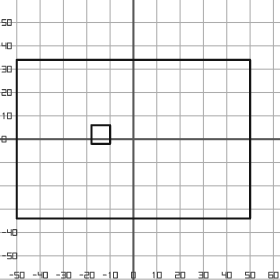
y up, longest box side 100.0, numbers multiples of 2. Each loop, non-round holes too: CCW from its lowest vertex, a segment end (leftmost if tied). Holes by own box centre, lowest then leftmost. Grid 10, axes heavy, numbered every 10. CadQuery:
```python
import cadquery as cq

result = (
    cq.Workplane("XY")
    .moveTo(-50.0, -34.0)
    .lineTo(50.0, -34.0)
    .lineTo(50.0, 34.0)
    .lineTo(-50.0, 34.0)
    .close()
    .moveTo(-18.0, -2.0)
    .lineTo(-10.0, -2.0)
    .lineTo(-10.0, 6.0)
    .lineTo(-18.0, 6.0)
    .close()
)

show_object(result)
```